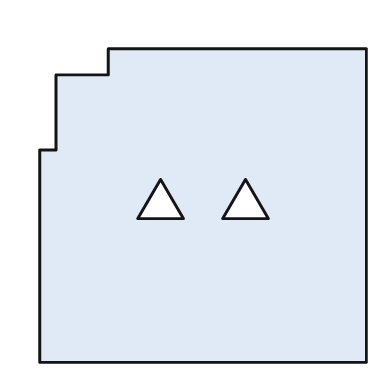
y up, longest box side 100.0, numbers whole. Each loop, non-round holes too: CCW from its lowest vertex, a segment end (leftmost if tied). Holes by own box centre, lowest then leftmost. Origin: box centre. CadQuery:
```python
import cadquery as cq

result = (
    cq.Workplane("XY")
    .moveTo(-50.0, -48.0)
    .lineTo(50.0, -48.0)
    .lineTo(50.0, 48.0)
    .lineTo(-29.0, 48.0)
    .lineTo(-29.0, 40.0)
    .lineTo(-45.0, 40.0)
    .lineTo(-45.0, 17.0)
    .lineTo(-50.0, 17.0)
    .close()
    .moveTo(-20.0, -4.0)
    .lineTo(-6.0, -4.0)
    .lineTo(-13.0, 8.0)
    .close()
    .moveTo(6.0, -4.0)
    .lineTo(20.0, -4.0)
    .lineTo(13.0, 8.0)
    .close()
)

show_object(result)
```